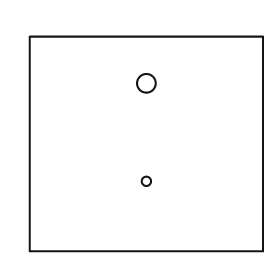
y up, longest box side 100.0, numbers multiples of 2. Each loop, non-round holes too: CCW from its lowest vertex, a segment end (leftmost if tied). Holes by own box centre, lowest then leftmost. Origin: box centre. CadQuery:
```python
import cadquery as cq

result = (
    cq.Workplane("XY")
    .moveTo(-50.0, -46.0)
    .lineTo(50.0, -46.0)
    .lineTo(50.0, 46.0)
    .lineTo(-50.0, 46.0)
    .close()
    .moveTo(0.0, -16.0)
    .circle(2.0)
    .moveTo(0.0, 26.0)
    .circle(4.0)
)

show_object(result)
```